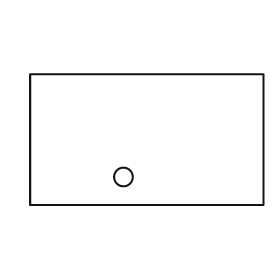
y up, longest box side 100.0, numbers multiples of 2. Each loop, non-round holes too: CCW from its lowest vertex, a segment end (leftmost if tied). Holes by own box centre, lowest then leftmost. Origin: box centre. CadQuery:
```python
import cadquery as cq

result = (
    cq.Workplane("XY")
    .moveTo(-50.0, -28.0)
    .lineTo(50.0, -28.0)
    .lineTo(50.0, 28.0)
    .lineTo(-50.0, 28.0)
    .close()
    .moveTo(-10.0, -16.0)
    .circle(4.0)
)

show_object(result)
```